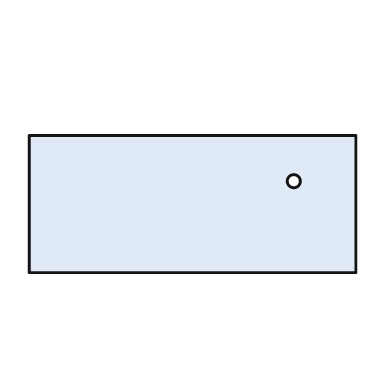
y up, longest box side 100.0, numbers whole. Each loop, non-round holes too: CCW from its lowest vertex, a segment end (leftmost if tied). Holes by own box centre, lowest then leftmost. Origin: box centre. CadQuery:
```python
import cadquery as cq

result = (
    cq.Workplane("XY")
    .moveTo(-50.0, -21.0)
    .lineTo(50.0, -21.0)
    .lineTo(50.0, 21.0)
    .lineTo(-50.0, 21.0)
    .close()
    .moveTo(31.0, 7.0)
    .circle(2.0)
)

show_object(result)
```